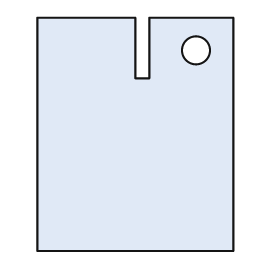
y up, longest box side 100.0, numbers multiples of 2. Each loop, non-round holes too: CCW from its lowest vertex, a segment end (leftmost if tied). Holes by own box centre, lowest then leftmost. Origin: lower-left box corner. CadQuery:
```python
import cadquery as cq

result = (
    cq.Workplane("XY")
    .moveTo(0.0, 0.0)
    .lineTo(84.0, 0.0)
    .lineTo(84.0, 100.0)
    .lineTo(48.0, 100.0)
    .lineTo(48.0, 74.0)
    .lineTo(42.0, 74.0)
    .lineTo(42.0, 100.0)
    .lineTo(0.0, 100.0)
    .close()
    .moveTo(68.0, 86.0)
    .circle(6.0)
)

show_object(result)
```